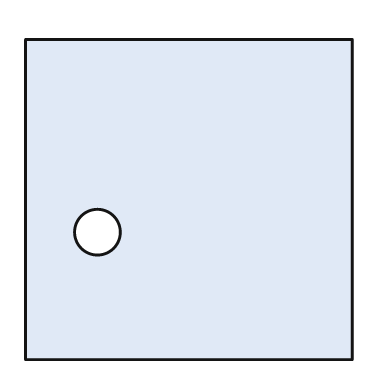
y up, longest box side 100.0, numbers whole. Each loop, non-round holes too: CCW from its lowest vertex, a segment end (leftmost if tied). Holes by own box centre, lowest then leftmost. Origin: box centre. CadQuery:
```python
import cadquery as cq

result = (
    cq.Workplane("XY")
    .moveTo(-50.0, -49.0)
    .lineTo(50.0, -49.0)
    .lineTo(50.0, 49.0)
    .lineTo(-50.0, 49.0)
    .close()
    .moveTo(-28.0, -10.0)
    .circle(7.0)
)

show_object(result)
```